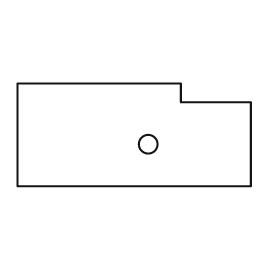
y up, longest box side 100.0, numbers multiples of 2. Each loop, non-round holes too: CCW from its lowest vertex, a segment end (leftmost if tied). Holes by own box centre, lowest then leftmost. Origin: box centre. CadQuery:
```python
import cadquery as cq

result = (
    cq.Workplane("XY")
    .moveTo(-50.0, -22.0)
    .lineTo(50.0, -22.0)
    .lineTo(50.0, 14.0)
    .lineTo(20.0, 14.0)
    .lineTo(20.0, 22.0)
    .lineTo(-50.0, 22.0)
    .close()
    .moveTo(6.0, -4.0)
    .circle(4.0)
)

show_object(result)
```